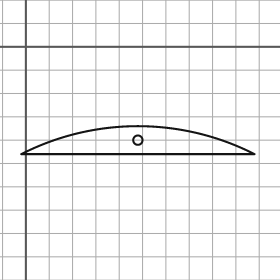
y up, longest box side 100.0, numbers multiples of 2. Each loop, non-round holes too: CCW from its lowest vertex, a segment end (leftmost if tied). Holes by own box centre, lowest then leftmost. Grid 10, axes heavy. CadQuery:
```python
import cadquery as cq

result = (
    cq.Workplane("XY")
    .moveTo(-2.0, -46.0)
    .lineTo(98.0, -46.0)
    .threePointArc((48.0, -34.0), (-2.0, -46.0))
    .close()
    .moveTo(48.0, -40.0)
    .circle(2.0)
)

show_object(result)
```